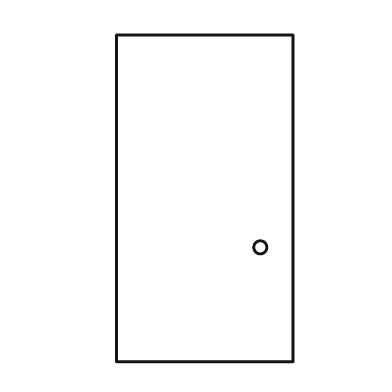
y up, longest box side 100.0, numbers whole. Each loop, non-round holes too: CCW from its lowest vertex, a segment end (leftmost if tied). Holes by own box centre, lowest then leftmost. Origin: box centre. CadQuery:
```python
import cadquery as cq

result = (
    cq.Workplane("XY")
    .moveTo(-27.0, -50.0)
    .lineTo(27.0, -50.0)
    .lineTo(27.0, 50.0)
    .lineTo(-27.0, 50.0)
    .close()
    .moveTo(17.0, -15.0)
    .circle(2.0)
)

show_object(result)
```